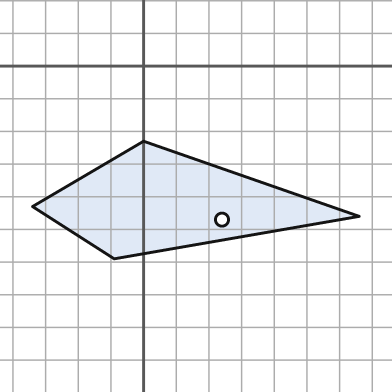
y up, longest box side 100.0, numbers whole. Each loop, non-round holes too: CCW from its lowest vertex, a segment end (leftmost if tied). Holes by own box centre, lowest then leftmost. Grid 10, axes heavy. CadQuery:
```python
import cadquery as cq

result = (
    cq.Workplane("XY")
    .moveTo(-9.0, -59.0)
    .lineTo(66.0, -46.0)
    .lineTo(0.0, -23.0)
    .lineTo(-34.0, -43.0)
    .close()
    .moveTo(24.0, -47.0)
    .circle(2.0)
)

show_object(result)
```